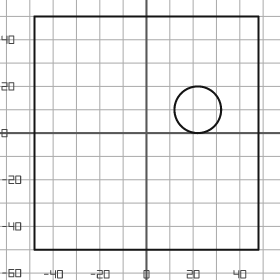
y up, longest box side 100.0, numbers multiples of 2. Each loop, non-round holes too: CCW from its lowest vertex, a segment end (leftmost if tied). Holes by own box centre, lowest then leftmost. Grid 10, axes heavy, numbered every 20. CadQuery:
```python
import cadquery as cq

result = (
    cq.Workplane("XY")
    .moveTo(-48.0, -50.0)
    .lineTo(48.0, -50.0)
    .lineTo(48.0, 50.0)
    .lineTo(-48.0, 50.0)
    .close()
    .moveTo(22.0, 10.0)
    .circle(10.0)
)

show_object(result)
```